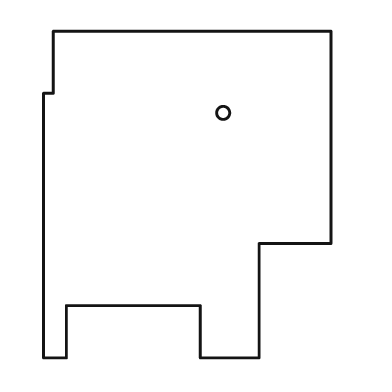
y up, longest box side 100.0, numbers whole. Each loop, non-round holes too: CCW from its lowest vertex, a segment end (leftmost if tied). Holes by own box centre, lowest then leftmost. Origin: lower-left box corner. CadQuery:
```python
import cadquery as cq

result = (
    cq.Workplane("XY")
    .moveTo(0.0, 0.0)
    .lineTo(7.0, 0.0)
    .lineTo(7.0, 16.0)
    .lineTo(48.0, 16.0)
    .lineTo(48.0, 0.0)
    .lineTo(66.0, 0.0)
    .lineTo(66.0, 35.0)
    .lineTo(88.0, 35.0)
    .lineTo(88.0, 100.0)
    .lineTo(3.0, 100.0)
    .lineTo(3.0, 81.0)
    .lineTo(0.0, 81.0)
    .close()
    .moveTo(55.0, 75.0)
    .circle(2.0)
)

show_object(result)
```